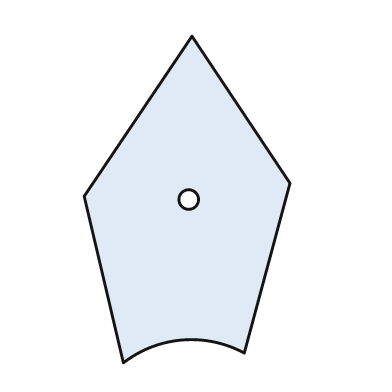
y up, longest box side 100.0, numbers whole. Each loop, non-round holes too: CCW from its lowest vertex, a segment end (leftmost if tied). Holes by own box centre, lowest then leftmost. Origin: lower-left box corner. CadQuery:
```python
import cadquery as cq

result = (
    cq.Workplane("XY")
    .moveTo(12.0, 0.0)
    .threePointArc((30.0, 7.0), (49.0, 3.0))
    .lineTo(63.0, 55.0)
    .lineTo(33.0, 100.0)
    .lineTo(0.0, 51.0)
    .close()
    .moveTo(32.0, 50.0)
    .circle(3.0)
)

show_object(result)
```